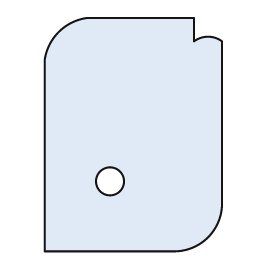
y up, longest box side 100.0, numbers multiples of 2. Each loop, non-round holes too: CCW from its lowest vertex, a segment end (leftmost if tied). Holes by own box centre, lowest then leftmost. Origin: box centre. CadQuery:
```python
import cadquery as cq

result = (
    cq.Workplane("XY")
    .moveTo(-38.0, -50.0)
    .lineTo(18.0, -50.0)
    .threePointArc((32.0, -44.0), (38.0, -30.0))
    .lineTo(38.0, 40.0)
    .threePointArc((32.0, 42.0), (26.0, 40.0))
    .lineTo(26.0, 50.0)
    .lineTo(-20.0, 50.0)
    .threePointArc((-32.0, 44.0), (-38.0, 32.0))
    .close()
    .moveTo(-10.0, -20.0)
    .circle(6.0)
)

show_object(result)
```